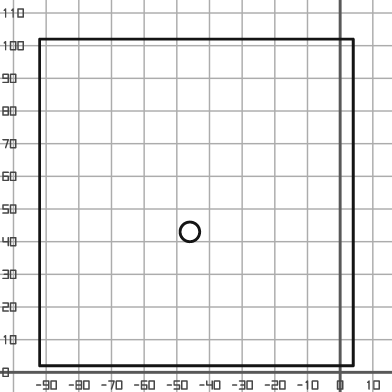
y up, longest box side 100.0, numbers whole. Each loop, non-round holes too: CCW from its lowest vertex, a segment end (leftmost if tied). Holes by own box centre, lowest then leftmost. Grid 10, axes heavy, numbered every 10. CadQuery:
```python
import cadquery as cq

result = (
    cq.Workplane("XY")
    .moveTo(-92.0, 2.0)
    .lineTo(4.0, 2.0)
    .lineTo(4.0, 102.0)
    .lineTo(-92.0, 102.0)
    .close()
    .moveTo(-46.0, 43.0)
    .circle(3.0)
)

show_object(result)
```